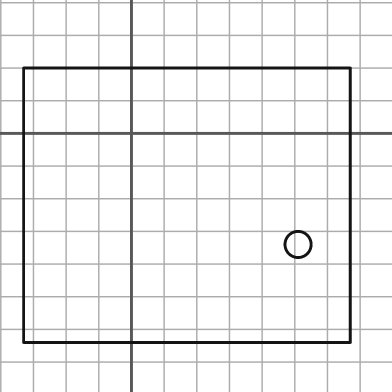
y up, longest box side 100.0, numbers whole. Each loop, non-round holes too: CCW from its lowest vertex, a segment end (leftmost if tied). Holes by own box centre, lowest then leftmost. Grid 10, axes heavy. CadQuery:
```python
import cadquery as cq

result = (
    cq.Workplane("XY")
    .moveTo(-33.0, -64.0)
    .lineTo(67.0, -64.0)
    .lineTo(67.0, 20.0)
    .lineTo(-33.0, 20.0)
    .close()
    .moveTo(51.0, -34.0)
    .circle(4.0)
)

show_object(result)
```